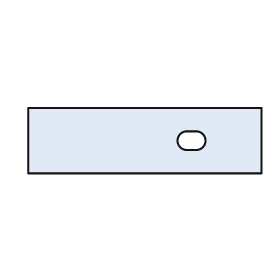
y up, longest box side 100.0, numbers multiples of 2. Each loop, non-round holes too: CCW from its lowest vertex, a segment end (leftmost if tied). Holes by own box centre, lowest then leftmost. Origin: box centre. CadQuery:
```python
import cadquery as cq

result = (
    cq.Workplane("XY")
    .moveTo(-50.0, -14.0)
    .lineTo(50.0, -14.0)
    .lineTo(50.0, 14.0)
    .lineTo(-50.0, 14.0)
    .close()
    .moveTo(18.0, -4.0)
    .lineTo(22.0, -4.0)
    .threePointArc((26.0, 0.0), (22.0, 4.0))
    .lineTo(18.0, 4.0)
    .threePointArc((14.0, 0.0), (18.0, -4.0))
    .close()
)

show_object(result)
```